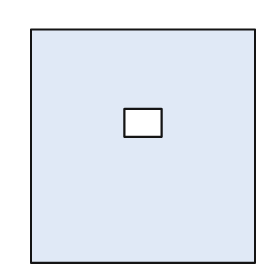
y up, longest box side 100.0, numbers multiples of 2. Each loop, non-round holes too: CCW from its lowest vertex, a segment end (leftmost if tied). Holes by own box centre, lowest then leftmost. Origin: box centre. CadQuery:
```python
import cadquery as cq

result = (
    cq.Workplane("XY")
    .moveTo(-48.0, -50.0)
    .lineTo(48.0, -50.0)
    .lineTo(48.0, 50.0)
    .lineTo(-48.0, 50.0)
    .close()
    .moveTo(-8.0, 4.0)
    .lineTo(8.0, 4.0)
    .lineTo(8.0, 16.0)
    .lineTo(-8.0, 16.0)
    .close()
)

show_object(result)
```